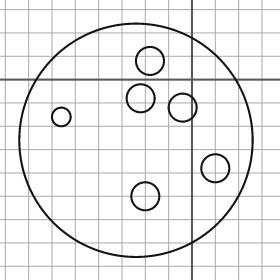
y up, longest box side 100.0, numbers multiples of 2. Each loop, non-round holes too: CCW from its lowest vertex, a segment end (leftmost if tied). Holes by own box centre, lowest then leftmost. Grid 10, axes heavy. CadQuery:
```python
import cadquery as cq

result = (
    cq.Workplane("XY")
    .moveTo(-24.0, -26.0)
    .circle(50.0)
    .moveTo(-20.0, -50.0)
    .circle(6.0)
    .moveTo(10.0, -38.0)
    .circle(6.0)
    .moveTo(-56.0, -16.0)
    .circle(4.0)
    .moveTo(-4.0, -12.0)
    .circle(6.0)
    .moveTo(-22.0, -8.0)
    .circle(6.0)
    .moveTo(-18.0, 8.0)
    .circle(6.0)
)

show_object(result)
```